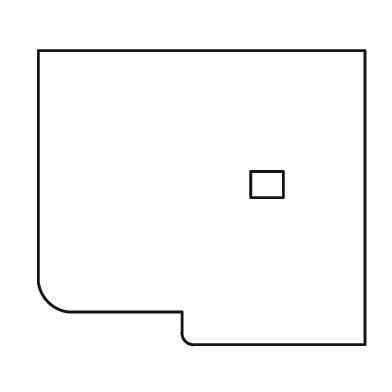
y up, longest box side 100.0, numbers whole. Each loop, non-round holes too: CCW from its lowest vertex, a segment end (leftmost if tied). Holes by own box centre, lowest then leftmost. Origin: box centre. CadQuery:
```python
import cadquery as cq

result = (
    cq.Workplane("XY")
    .moveTo(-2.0, -45.0)
    .lineTo(50.0, -45.0)
    .lineTo(50.0, 45.0)
    .lineTo(-50.0, 45.0)
    .lineTo(-50.0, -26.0)
    .threePointArc((-47.0, -32.0), (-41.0, -35.0))
    .lineTo(-6.0, -35.0)
    .lineTo(-6.0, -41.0)
    .threePointArc((-5.0, -44.0), (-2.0, -45.0))
    .close()
    .moveTo(15.0, 0.0)
    .lineTo(25.0, 0.0)
    .lineTo(25.0, 8.0)
    .lineTo(15.0, 8.0)
    .close()
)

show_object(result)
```